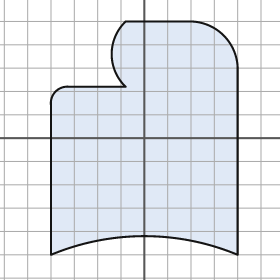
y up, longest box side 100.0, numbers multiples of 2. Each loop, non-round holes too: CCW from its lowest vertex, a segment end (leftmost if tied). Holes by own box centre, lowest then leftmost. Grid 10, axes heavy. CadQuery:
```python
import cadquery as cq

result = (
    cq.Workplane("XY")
    .moveTo(-40.0, -50.0)
    .threePointArc((0.0, -42.0), (40.0, -50.0))
    .lineTo(40.0, 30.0)
    .threePointArc((34.0, 44.0), (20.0, 50.0))
    .lineTo(-8.0, 50.0)
    .threePointArc((-14.0, 36.0), (-8.0, 22.0))
    .lineTo(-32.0, 22.0)
    .threePointArc((-38.0, 20.0), (-40.0, 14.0))
    .close()
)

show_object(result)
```